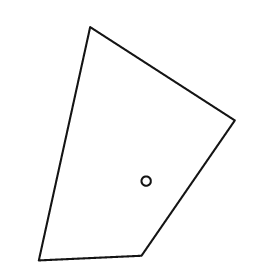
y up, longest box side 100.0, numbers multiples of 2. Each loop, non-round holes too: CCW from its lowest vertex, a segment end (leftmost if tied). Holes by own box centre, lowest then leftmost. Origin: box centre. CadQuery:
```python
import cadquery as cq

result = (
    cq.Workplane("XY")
    .moveTo(-42.0, -50.0)
    .lineTo(2.0, -48.0)
    .lineTo(42.0, 10.0)
    .lineTo(-20.0, 50.0)
    .close()
    .moveTo(4.0, -16.0)
    .circle(2.0)
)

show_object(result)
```